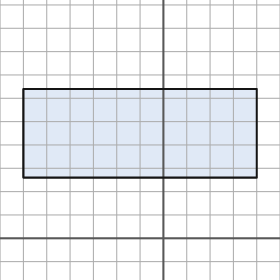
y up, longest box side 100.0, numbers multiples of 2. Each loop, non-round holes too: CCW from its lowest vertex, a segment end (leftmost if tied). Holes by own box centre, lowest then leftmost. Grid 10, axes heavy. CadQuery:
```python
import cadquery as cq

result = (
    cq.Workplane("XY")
    .moveTo(-60.0, 26.0)
    .lineTo(40.0, 26.0)
    .lineTo(40.0, 64.0)
    .lineTo(-60.0, 64.0)
    .close()
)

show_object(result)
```